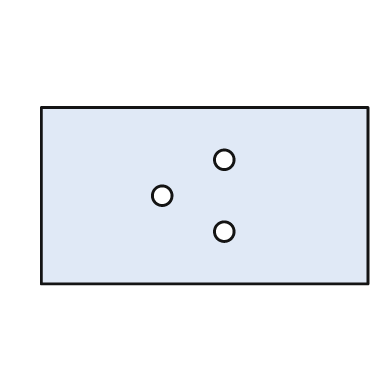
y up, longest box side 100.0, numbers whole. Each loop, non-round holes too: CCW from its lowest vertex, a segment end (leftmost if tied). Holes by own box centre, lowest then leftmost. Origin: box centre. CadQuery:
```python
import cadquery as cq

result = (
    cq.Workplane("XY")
    .moveTo(-50.0, -27.0)
    .lineTo(50.0, -27.0)
    .lineTo(50.0, 27.0)
    .lineTo(-50.0, 27.0)
    .close()
    .moveTo(6.0, -11.0)
    .circle(3.0)
    .moveTo(-13.0, 0.0)
    .circle(3.0)
    .moveTo(6.0, 11.0)
    .circle(3.0)
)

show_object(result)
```